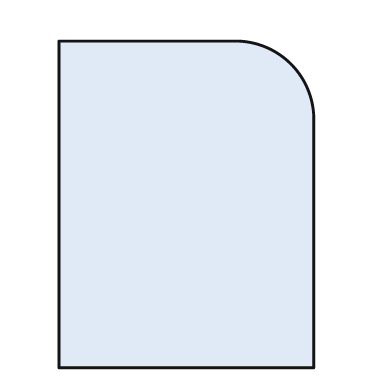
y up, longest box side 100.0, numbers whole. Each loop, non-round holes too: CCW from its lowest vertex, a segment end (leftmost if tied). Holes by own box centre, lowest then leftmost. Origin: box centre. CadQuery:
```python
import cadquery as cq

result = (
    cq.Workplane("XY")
    .moveTo(-39.0, -50.0)
    .lineTo(39.0, -50.0)
    .lineTo(39.0, 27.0)
    .threePointArc((32.0, 43.0), (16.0, 50.0))
    .lineTo(-39.0, 50.0)
    .close()
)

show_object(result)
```